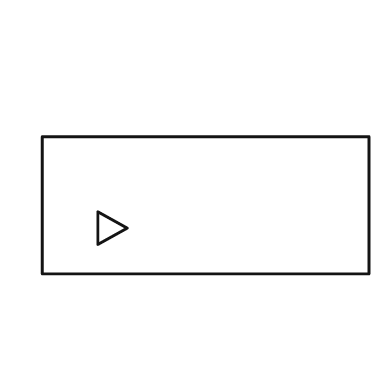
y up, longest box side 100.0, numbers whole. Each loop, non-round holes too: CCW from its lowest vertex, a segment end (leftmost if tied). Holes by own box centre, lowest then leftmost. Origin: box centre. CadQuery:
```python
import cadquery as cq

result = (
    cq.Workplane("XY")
    .moveTo(-50.0, -21.0)
    .lineTo(50.0, -21.0)
    .lineTo(50.0, 21.0)
    .lineTo(-50.0, 21.0)
    .close()
    .moveTo(-33.0, -12.0)
    .lineTo(-24.0, -7.0)
    .lineTo(-33.0, -2.0)
    .close()
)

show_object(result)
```